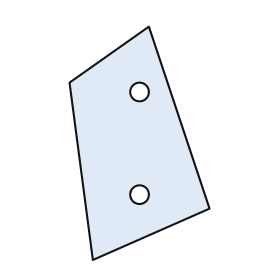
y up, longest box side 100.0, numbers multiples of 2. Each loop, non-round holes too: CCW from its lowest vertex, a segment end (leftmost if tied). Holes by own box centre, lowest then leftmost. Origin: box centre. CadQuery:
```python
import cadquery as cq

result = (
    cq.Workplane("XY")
    .moveTo(-20.0, -50.0)
    .lineTo(30.0, -28.0)
    .lineTo(4.0, 50.0)
    .lineTo(-30.0, 26.0)
    .close()
    .moveTo(0.0, -22.0)
    .circle(4.0)
    .moveTo(0.0, 22.0)
    .circle(4.0)
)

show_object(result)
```